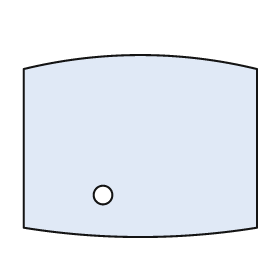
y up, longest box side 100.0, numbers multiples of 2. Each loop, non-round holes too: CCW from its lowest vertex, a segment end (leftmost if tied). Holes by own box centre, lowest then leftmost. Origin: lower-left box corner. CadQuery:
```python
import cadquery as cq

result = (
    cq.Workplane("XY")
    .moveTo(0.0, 4.0)
    .threePointArc((50.0, 0.0), (100.0, 4.0))
    .lineTo(100.0, 72.0)
    .threePointArc((50.0, 78.0), (0.0, 72.0))
    .close()
    .moveTo(34.0, 18.0)
    .circle(4.0)
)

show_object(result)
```